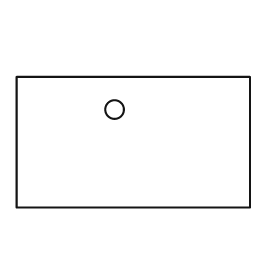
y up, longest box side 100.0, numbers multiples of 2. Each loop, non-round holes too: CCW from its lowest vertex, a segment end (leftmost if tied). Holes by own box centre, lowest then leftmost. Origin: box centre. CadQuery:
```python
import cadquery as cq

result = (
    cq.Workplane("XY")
    .moveTo(-50.0, -28.0)
    .lineTo(50.0, -28.0)
    .lineTo(50.0, 28.0)
    .lineTo(-50.0, 28.0)
    .close()
    .moveTo(-8.0, 14.0)
    .circle(4.0)
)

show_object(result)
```